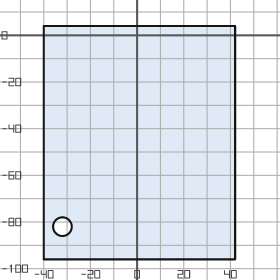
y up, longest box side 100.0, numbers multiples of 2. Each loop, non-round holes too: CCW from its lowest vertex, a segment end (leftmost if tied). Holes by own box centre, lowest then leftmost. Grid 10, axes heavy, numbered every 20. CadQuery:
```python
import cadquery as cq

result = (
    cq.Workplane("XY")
    .moveTo(-40.0, -96.0)
    .lineTo(42.0, -96.0)
    .lineTo(42.0, 4.0)
    .lineTo(-40.0, 4.0)
    .close()
    .moveTo(-32.0, -82.0)
    .circle(4.0)
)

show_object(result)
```